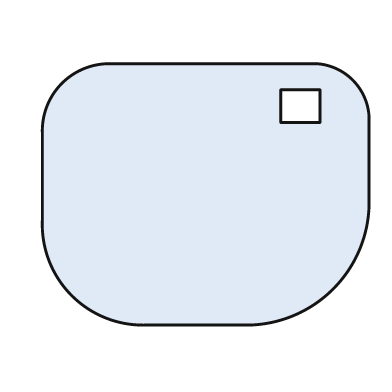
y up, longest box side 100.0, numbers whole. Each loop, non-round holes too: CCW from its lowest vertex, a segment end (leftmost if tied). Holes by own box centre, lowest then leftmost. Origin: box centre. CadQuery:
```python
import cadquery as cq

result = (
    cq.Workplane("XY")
    .moveTo(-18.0, -40.0)
    .lineTo(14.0, -40.0)
    .threePointArc((39.0, -29.0), (50.0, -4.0))
    .lineTo(50.0, 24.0)
    .threePointArc((45.0, 35.0), (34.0, 40.0))
    .lineTo(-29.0, 40.0)
    .threePointArc((-44.0, 34.0), (-50.0, 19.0))
    .lineTo(-50.0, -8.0)
    .threePointArc((-41.0, -31.0), (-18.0, -40.0))
    .close()
    .moveTo(23.0, 22.0)
    .lineTo(35.0, 22.0)
    .lineTo(35.0, 32.0)
    .lineTo(23.0, 32.0)
    .close()
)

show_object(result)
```